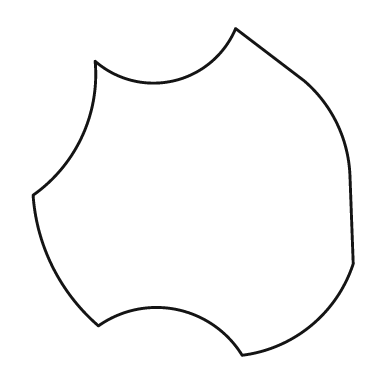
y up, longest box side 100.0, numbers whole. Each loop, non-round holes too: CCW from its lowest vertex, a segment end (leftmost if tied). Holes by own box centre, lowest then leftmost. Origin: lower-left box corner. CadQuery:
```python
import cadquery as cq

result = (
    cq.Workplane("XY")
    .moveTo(64.0, 0.0)
    .threePointArc((85.0, 9.0), (98.0, 28.0))
    .lineTo(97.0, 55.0)
    .threePointArc((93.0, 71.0), (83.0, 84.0))
    .lineTo(62.0, 100.0)
    .threePointArc((43.0, 84.0), (19.0, 90.0))
    .threePointArc((15.0, 67.0), (0.0, 49.0))
    .threePointArc((6.0, 27.0), (20.0, 9.0))
    .threePointArc((44.0, 14.0), (64.0, 0.0))
    .close()
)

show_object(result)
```